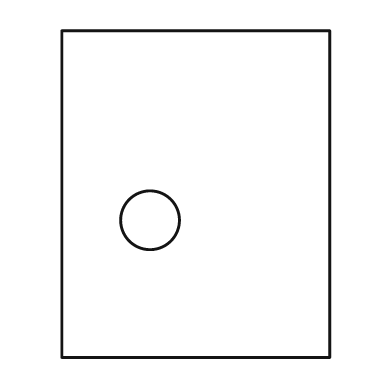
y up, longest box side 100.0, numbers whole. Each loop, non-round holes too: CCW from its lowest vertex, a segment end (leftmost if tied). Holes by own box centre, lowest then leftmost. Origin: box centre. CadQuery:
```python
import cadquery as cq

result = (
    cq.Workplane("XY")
    .moveTo(-41.0, -50.0)
    .lineTo(41.0, -50.0)
    .lineTo(41.0, 50.0)
    .lineTo(-41.0, 50.0)
    .close()
    .moveTo(-14.0, -8.0)
    .circle(9.0)
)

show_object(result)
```